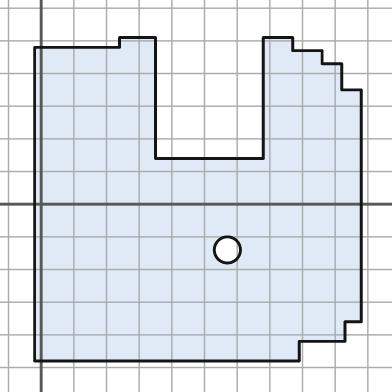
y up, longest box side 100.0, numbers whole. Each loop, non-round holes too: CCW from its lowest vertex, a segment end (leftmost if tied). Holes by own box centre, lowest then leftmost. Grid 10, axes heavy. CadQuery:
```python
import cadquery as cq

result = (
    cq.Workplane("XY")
    .moveTo(-2.0, -48.0)
    .lineTo(79.0, -48.0)
    .lineTo(79.0, -42.0)
    .lineTo(93.0, -42.0)
    .lineTo(93.0, -36.0)
    .lineTo(98.0, -36.0)
    .lineTo(98.0, 35.0)
    .lineTo(92.0, 35.0)
    .lineTo(92.0, 43.0)
    .lineTo(86.0, 43.0)
    .lineTo(86.0, 47.0)
    .lineTo(77.0, 47.0)
    .lineTo(77.0, 51.0)
    .lineTo(68.0, 51.0)
    .lineTo(68.0, 14.0)
    .lineTo(35.0, 14.0)
    .lineTo(35.0, 51.0)
    .lineTo(24.0, 51.0)
    .lineTo(24.0, 48.0)
    .lineTo(-2.0, 48.0)
    .close()
    .moveTo(57.0, -14.0)
    .circle(4.0)
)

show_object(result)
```